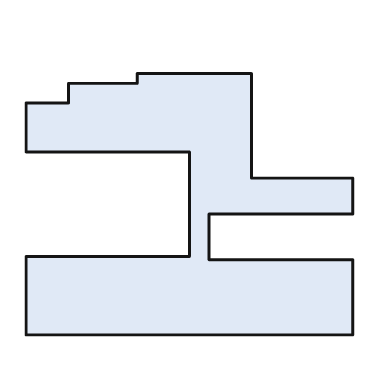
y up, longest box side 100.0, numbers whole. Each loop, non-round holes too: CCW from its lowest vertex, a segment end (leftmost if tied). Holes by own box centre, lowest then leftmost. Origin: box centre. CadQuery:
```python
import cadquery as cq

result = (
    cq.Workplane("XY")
    .moveTo(-50.0, -40.0)
    .lineTo(50.0, -40.0)
    .lineTo(50.0, -17.0)
    .lineTo(6.0, -17.0)
    .lineTo(6.0, -3.0)
    .lineTo(50.0, -3.0)
    .lineTo(50.0, 8.0)
    .lineTo(19.0, 8.0)
    .lineTo(19.0, 40.0)
    .lineTo(-16.0, 40.0)
    .lineTo(-16.0, 37.0)
    .lineTo(-37.0, 37.0)
    .lineTo(-37.0, 31.0)
    .lineTo(-50.0, 31.0)
    .lineTo(-50.0, 16.0)
    .lineTo(0.0, 16.0)
    .lineTo(0.0, -16.0)
    .lineTo(-50.0, -16.0)
    .close()
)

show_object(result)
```